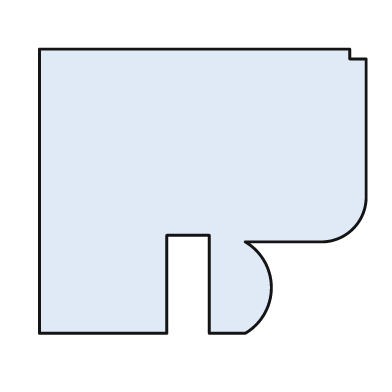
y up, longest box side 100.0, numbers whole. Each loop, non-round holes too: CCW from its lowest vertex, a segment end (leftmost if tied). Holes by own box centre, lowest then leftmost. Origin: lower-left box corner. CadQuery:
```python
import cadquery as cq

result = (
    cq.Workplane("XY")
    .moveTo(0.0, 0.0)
    .lineTo(39.0, 0.0)
    .lineTo(39.0, 30.0)
    .lineTo(52.0, 30.0)
    .lineTo(52.0, 0.0)
    .lineTo(63.0, 0.0)
    .threePointArc((71.0, 14.0), (63.0, 28.0))
    .lineTo(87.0, 28.0)
    .threePointArc((96.0, 32.0), (100.0, 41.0))
    .lineTo(100.0, 84.0)
    .lineTo(95.0, 84.0)
    .lineTo(95.0, 87.0)
    .lineTo(0.0, 87.0)
    .close()
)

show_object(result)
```